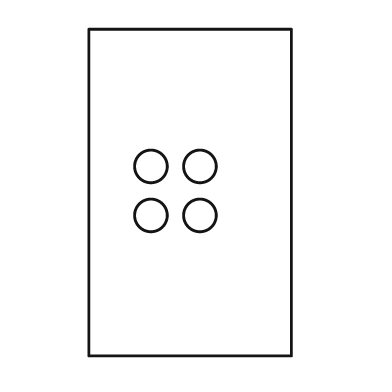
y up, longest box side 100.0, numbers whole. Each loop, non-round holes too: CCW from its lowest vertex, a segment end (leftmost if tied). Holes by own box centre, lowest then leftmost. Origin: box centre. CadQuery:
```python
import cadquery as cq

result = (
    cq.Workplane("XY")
    .moveTo(-31.0, -50.0)
    .lineTo(31.0, -50.0)
    .lineTo(31.0, 50.0)
    .lineTo(-31.0, 50.0)
    .close()
    .moveTo(-12.0, -7.0)
    .circle(5.0)
    .moveTo(3.0, -7.0)
    .circle(5.0)
    .moveTo(-12.0, 8.0)
    .circle(5.0)
    .moveTo(3.0, 8.0)
    .circle(5.0)
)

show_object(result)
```